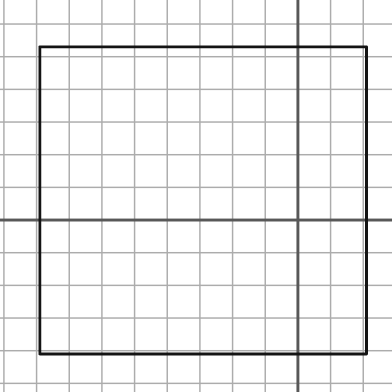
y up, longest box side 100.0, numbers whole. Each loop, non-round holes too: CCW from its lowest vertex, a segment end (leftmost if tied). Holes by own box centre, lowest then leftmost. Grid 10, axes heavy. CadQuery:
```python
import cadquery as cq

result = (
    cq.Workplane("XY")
    .moveTo(-79.0, -41.0)
    .lineTo(21.0, -41.0)
    .lineTo(21.0, 53.0)
    .lineTo(-79.0, 53.0)
    .close()
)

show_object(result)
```